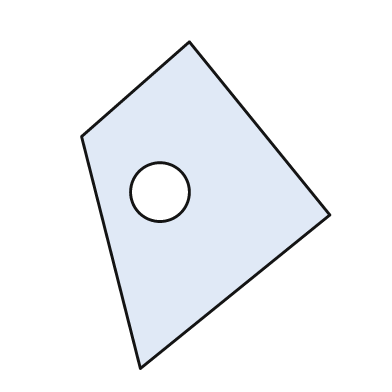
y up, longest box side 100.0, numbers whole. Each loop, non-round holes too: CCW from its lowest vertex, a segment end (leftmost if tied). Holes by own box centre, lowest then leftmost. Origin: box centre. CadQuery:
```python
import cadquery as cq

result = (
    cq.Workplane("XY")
    .moveTo(-20.0, -50.0)
    .lineTo(38.0, -3.0)
    .lineTo(-5.0, 50.0)
    .lineTo(-38.0, 21.0)
    .close()
    .moveTo(-14.0, 4.0)
    .circle(9.0)
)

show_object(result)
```